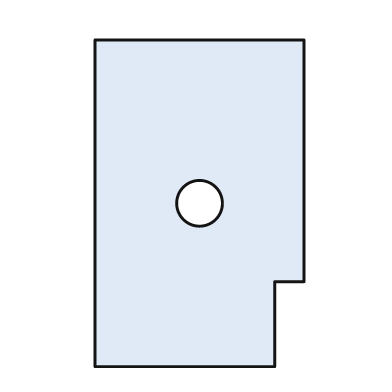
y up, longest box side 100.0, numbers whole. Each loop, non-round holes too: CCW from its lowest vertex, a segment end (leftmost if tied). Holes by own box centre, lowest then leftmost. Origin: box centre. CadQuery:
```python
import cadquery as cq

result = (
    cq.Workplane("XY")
    .moveTo(-32.0, -50.0)
    .lineTo(23.0, -50.0)
    .lineTo(23.0, -24.0)
    .lineTo(32.0, -24.0)
    .lineTo(32.0, 50.0)
    .lineTo(-32.0, 50.0)
    .close()
    .moveTo(0.0, 0.0)
    .circle(7.0)
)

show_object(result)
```